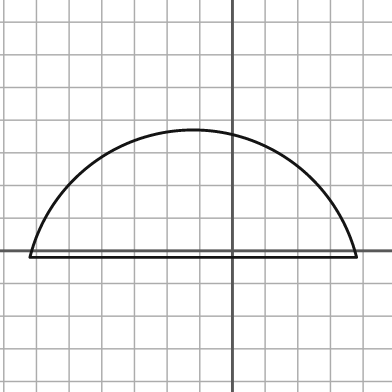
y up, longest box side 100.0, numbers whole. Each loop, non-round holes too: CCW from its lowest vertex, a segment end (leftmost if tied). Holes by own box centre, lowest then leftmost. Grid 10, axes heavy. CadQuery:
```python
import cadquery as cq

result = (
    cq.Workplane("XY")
    .moveTo(-62.0, -2.0)
    .lineTo(38.0, -2.0)
    .threePointArc((-12.0, 37.0), (-62.0, -2.0))
    .close()
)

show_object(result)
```